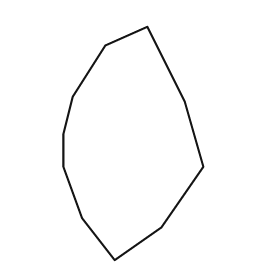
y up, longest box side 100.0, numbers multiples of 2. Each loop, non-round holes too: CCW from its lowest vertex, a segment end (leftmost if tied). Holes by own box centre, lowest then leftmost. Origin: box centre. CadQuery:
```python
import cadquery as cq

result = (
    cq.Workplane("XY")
    .moveTo(-8.0, -50.0)
    .lineTo(12.0, -36.0)
    .lineTo(30.0, -10.0)
    .lineTo(22.0, 18.0)
    .lineTo(6.0, 50.0)
    .lineTo(-12.0, 42.0)
    .lineTo(-26.0, 20.0)
    .lineTo(-30.0, 4.0)
    .lineTo(-30.0, -10.0)
    .lineTo(-22.0, -32.0)
    .close()
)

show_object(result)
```